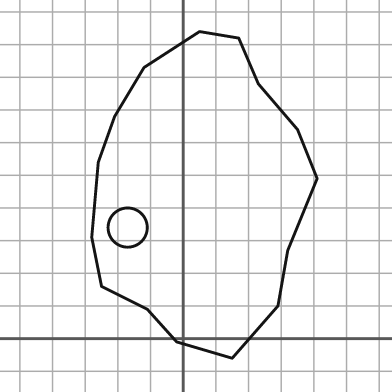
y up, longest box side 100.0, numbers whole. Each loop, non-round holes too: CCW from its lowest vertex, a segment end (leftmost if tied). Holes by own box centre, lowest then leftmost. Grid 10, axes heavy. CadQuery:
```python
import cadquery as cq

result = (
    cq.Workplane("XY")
    .moveTo(15.0, -6.0)
    .lineTo(29.0, 10.0)
    .lineTo(32.0, 27.0)
    .lineTo(41.0, 49.0)
    .lineTo(35.0, 64.0)
    .lineTo(23.0, 78.0)
    .lineTo(17.0, 92.0)
    .lineTo(5.0, 94.0)
    .lineTo(-12.0, 83.0)
    .lineTo(-21.0, 68.0)
    .lineTo(-26.0, 54.0)
    .lineTo(-28.0, 31.0)
    .lineTo(-25.0, 16.0)
    .lineTo(-11.0, 9.0)
    .lineTo(-2.0, -1.0)
    .close()
    .moveTo(-17.0, 34.0)
    .circle(6.0)
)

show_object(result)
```